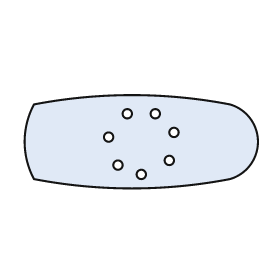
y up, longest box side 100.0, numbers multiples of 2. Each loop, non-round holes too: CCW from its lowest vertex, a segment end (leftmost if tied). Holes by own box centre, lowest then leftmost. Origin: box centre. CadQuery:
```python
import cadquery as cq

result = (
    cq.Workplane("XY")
    .moveTo(-46.0, -16.0)
    .threePointArc((-4.0, -20.0), (38.0, -16.0))
    .threePointArc((50.0, 0.0), (38.0, 16.0))
    .threePointArc((-4.0, 20.0), (-46.0, 16.0))
    .threePointArc((-50.0, 0.0), (-46.0, -16.0))
    .close()
    .moveTo(0.0, -14.0)
    .circle(2.0)
    .moveTo(-10.0, -10.0)
    .circle(2.0)
    .moveTo(12.0, -8.0)
    .circle(2.0)
    .moveTo(-14.0, 2.0)
    .circle(2.0)
    .moveTo(14.0, 4.0)
    .circle(2.0)
    .moveTo(-6.0, 12.0)
    .circle(2.0)
    .moveTo(6.0, 12.0)
    .circle(2.0)
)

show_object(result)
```